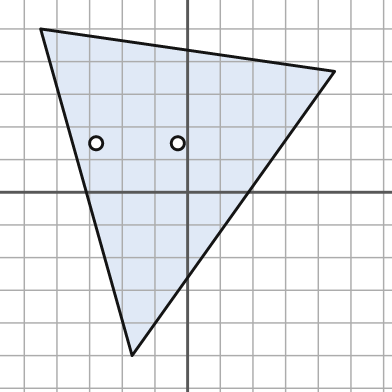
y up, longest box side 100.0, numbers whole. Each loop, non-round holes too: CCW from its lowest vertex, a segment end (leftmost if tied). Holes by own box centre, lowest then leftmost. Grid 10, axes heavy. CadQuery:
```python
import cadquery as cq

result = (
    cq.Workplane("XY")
    .moveTo(-17.0, -50.0)
    .lineTo(45.0, 37.0)
    .lineTo(-45.0, 50.0)
    .close()
    .moveTo(-28.0, 15.0)
    .circle(2.0)
    .moveTo(-3.0, 15.0)
    .circle(2.0)
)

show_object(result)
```